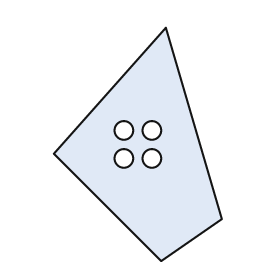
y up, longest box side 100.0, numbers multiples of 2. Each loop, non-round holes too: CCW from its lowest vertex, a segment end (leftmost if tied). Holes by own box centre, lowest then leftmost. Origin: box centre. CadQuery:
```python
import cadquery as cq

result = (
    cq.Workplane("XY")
    .moveTo(10.0, -50.0)
    .lineTo(36.0, -32.0)
    .lineTo(12.0, 50.0)
    .lineTo(-36.0, -4.0)
    .close()
    .moveTo(-6.0, -6.0)
    .circle(4.0)
    .moveTo(6.0, -6.0)
    .circle(4.0)
    .moveTo(-6.0, 6.0)
    .circle(4.0)
    .moveTo(6.0, 6.0)
    .circle(4.0)
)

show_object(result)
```